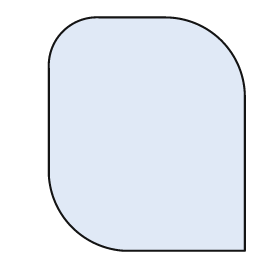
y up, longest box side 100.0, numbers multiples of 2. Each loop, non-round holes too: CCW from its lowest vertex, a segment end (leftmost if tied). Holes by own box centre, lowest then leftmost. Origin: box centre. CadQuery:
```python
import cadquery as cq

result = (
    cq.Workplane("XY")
    .moveTo(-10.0, -50.0)
    .lineTo(42.0, -50.0)
    .lineTo(42.0, 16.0)
    .threePointArc((32.0, 40.0), (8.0, 50.0))
    .lineTo(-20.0, 50.0)
    .threePointArc((-36.0, 44.0), (-42.0, 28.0))
    .lineTo(-42.0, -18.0)
    .threePointArc((-32.0, -40.0), (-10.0, -50.0))
    .close()
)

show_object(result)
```